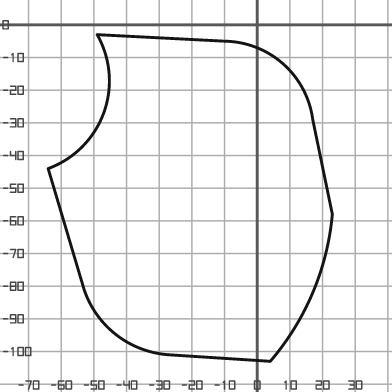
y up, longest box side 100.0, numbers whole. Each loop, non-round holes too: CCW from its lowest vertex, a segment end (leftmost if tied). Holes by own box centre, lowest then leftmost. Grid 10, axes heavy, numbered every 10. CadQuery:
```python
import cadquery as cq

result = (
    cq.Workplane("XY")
    .moveTo(4.0, -103.0)
    .threePointArc((17.0, -82.0), (23.0, -58.0))
    .lineTo(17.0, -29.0)
    .threePointArc((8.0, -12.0), (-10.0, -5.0))
    .lineTo(-49.0, -3.0)
    .threePointArc((-47.0, -27.0), (-64.0, -44.0))
    .lineTo(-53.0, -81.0)
    .threePointArc((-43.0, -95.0), (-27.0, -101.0))
    .close()
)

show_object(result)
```